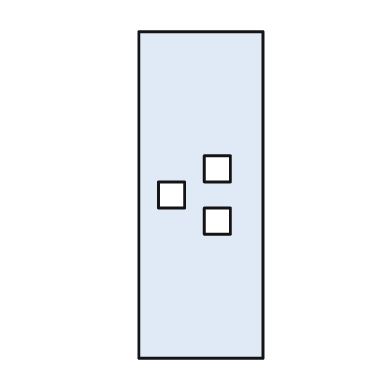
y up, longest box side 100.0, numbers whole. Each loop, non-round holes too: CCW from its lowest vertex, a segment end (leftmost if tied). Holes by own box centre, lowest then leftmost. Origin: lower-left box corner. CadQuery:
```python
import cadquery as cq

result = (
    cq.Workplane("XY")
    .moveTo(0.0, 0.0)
    .lineTo(38.0, 0.0)
    .lineTo(38.0, 100.0)
    .lineTo(0.0, 100.0)
    .close()
    .moveTo(20.0, 38.0)
    .lineTo(28.0, 38.0)
    .lineTo(28.0, 46.0)
    .lineTo(20.0, 46.0)
    .close()
    .moveTo(6.0, 46.0)
    .lineTo(14.0, 46.0)
    .lineTo(14.0, 54.0)
    .lineTo(6.0, 54.0)
    .close()
    .moveTo(20.0, 54.0)
    .lineTo(28.0, 54.0)
    .lineTo(28.0, 62.0)
    .lineTo(20.0, 62.0)
    .close()
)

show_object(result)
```